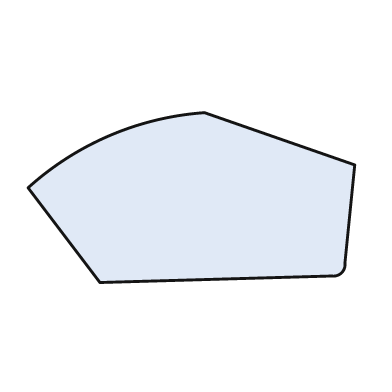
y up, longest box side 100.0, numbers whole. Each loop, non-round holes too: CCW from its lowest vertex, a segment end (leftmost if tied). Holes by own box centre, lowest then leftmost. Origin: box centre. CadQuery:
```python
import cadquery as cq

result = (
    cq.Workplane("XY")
    .moveTo(-28.0, -26.0)
    .lineTo(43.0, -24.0)
    .threePointArc((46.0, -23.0), (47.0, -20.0))
    .lineTo(50.0, 10.0)
    .lineTo(4.0, 26.0)
    .threePointArc((-25.0, 19.0), (-50.0, 3.0))
    .close()
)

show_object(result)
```